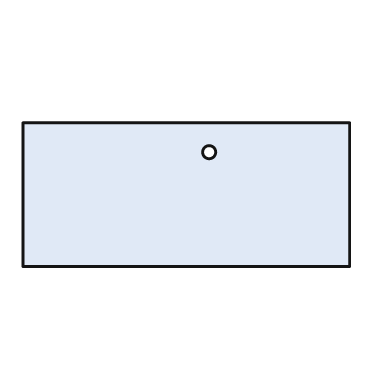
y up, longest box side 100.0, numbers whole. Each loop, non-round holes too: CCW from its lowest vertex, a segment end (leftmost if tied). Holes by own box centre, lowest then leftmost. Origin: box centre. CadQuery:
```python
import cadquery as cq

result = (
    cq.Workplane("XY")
    .moveTo(-50.0, -22.0)
    .lineTo(50.0, -22.0)
    .lineTo(50.0, 22.0)
    .lineTo(-50.0, 22.0)
    .close()
    .moveTo(7.0, 13.0)
    .circle(2.0)
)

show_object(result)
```